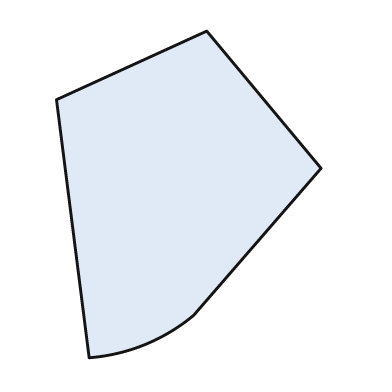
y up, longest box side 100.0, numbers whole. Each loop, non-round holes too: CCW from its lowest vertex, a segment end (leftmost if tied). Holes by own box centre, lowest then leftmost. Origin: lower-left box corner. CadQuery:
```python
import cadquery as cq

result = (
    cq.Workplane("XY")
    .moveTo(10.0, 0.0)
    .threePointArc((27.0, 4.0), (42.0, 13.0))
    .lineTo(81.0, 58.0)
    .lineTo(46.0, 100.0)
    .lineTo(0.0, 79.0)
    .close()
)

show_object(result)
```